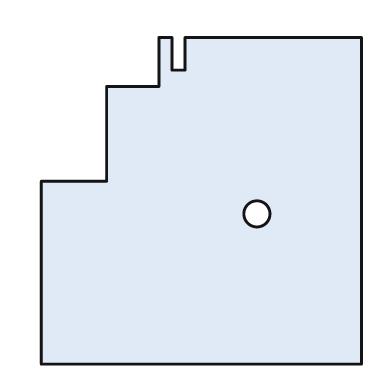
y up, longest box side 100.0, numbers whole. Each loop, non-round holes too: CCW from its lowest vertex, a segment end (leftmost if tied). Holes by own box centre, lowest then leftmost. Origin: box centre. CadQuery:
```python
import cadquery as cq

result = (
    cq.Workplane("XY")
    .moveTo(-49.0, -50.0)
    .lineTo(49.0, -50.0)
    .lineTo(49.0, 50.0)
    .lineTo(-5.0, 50.0)
    .lineTo(-5.0, 40.0)
    .lineTo(-9.0, 40.0)
    .lineTo(-9.0, 50.0)
    .lineTo(-13.0, 50.0)
    .lineTo(-13.0, 35.0)
    .lineTo(-29.0, 35.0)
    .lineTo(-29.0, 6.0)
    .lineTo(-49.0, 6.0)
    .close()
    .moveTo(17.0, -4.0)
    .circle(4.0)
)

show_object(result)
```